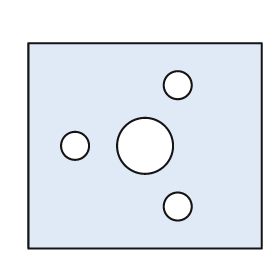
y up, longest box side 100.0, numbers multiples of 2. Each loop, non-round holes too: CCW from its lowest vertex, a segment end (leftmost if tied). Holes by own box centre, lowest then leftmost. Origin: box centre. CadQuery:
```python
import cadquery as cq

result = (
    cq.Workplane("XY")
    .moveTo(-50.0, -44.0)
    .lineTo(50.0, -44.0)
    .lineTo(50.0, 44.0)
    .lineTo(-50.0, 44.0)
    .close()
    .moveTo(14.0, -26.0)
    .circle(6.0)
    .moveTo(-30.0, 0.0)
    .circle(6.0)
    .moveTo(0.0, 0.0)
    .circle(12.0)
    .moveTo(14.0, 26.0)
    .circle(6.0)
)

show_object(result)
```